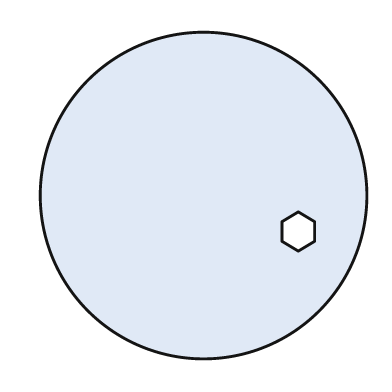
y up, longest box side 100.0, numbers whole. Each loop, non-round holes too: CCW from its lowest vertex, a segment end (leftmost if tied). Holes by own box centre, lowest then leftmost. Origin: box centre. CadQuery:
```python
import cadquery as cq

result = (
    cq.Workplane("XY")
    .moveTo(0.0, 0.0)
    .circle(50.0)
    .moveTo(29.0, -17.0)
    .lineTo(34.0, -14.0)
    .lineTo(34.0, -8.0)
    .lineTo(29.0, -5.0)
    .lineTo(24.0, -8.0)
    .lineTo(24.0, -14.0)
    .close()
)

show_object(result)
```